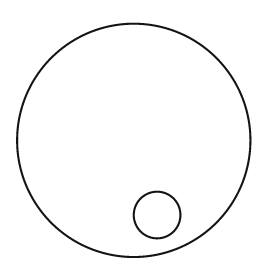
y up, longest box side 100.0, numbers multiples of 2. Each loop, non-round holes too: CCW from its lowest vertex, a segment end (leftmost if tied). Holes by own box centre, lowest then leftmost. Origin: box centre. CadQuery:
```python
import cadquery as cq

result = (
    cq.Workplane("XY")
    .moveTo(0.0, 0.0)
    .circle(50.0)
    .moveTo(10.0, -32.0)
    .circle(10.0)
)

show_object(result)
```